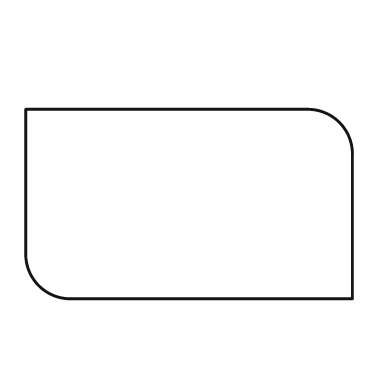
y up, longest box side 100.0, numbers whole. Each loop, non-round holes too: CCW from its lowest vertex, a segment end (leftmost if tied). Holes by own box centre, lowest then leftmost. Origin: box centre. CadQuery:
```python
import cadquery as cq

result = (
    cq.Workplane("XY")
    .moveTo(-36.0, -29.0)
    .lineTo(50.0, -29.0)
    .lineTo(50.0, 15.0)
    .threePointArc((46.0, 25.0), (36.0, 29.0))
    .lineTo(-50.0, 29.0)
    .lineTo(-50.0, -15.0)
    .threePointArc((-46.0, -25.0), (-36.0, -29.0))
    .close()
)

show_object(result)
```